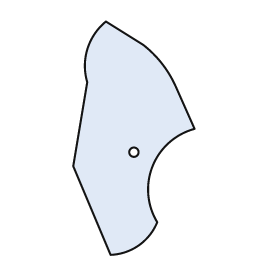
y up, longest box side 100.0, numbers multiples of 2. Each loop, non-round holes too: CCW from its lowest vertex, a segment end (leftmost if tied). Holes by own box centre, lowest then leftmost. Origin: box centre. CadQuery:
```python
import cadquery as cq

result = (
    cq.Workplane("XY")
    .moveTo(-10.0, -50.0)
    .threePointArc((2.0, -46.0), (10.0, -36.0))
    .threePointArc((8.0, -12.0), (26.0, 4.0))
    .lineTo(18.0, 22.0)
    .threePointArc((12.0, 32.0), (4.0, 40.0))
    .lineTo(-12.0, 50.0)
    .threePointArc((-20.0, 38.0), (-20.0, 24.0))
    .lineTo(-26.0, -12.0)
    .close()
    .moveTo(0.0, -6.0)
    .circle(2.0)
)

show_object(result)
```